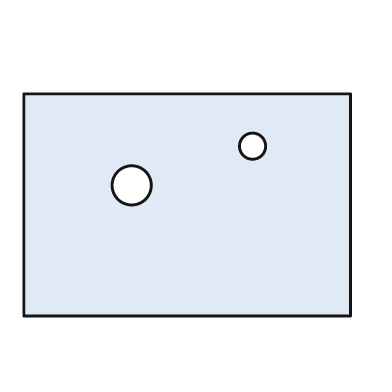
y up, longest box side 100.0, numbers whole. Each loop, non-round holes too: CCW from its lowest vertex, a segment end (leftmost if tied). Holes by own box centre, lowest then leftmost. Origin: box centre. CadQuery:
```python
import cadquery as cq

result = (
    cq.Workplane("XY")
    .moveTo(-50.0, -34.0)
    .lineTo(50.0, -34.0)
    .lineTo(50.0, 34.0)
    .lineTo(-50.0, 34.0)
    .close()
    .moveTo(-17.0, 6.0)
    .circle(6.0)
    .moveTo(20.0, 18.0)
    .circle(4.0)
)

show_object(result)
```